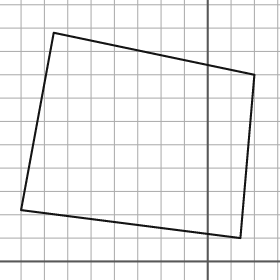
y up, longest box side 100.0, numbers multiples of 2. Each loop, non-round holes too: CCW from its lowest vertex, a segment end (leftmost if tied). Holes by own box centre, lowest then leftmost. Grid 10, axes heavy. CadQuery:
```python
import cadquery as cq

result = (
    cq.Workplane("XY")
    .moveTo(14.0, 10.0)
    .lineTo(20.0, 80.0)
    .lineTo(-66.0, 98.0)
    .lineTo(-80.0, 22.0)
    .close()
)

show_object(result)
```